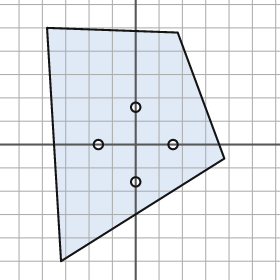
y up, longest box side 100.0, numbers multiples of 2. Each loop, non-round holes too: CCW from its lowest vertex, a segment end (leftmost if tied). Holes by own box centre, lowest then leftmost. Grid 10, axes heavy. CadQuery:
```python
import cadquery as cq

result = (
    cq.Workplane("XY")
    .moveTo(-32.0, -50.0)
    .lineTo(38.0, -6.0)
    .lineTo(18.0, 48.0)
    .lineTo(-38.0, 50.0)
    .close()
    .moveTo(0.0, -16.0)
    .circle(2.0)
    .moveTo(-16.0, 0.0)
    .circle(2.0)
    .moveTo(16.0, 0.0)
    .circle(2.0)
    .moveTo(0.0, 16.0)
    .circle(2.0)
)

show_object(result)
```